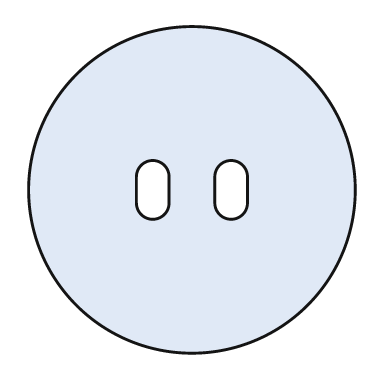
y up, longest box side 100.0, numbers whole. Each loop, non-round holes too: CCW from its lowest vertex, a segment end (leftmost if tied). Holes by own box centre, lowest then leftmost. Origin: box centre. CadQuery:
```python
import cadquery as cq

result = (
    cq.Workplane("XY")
    .moveTo(0.0, 0.0)
    .circle(50.0)
    .moveTo(-17.0, -4.0)
    .threePointArc((-12.0, -9.0), (-7.0, -4.0))
    .lineTo(-7.0, 4.0)
    .threePointArc((-12.0, 9.0), (-17.0, 4.0))
    .close()
    .moveTo(7.0, -4.0)
    .threePointArc((12.0, -9.0), (17.0, -4.0))
    .lineTo(17.0, 4.0)
    .threePointArc((12.0, 9.0), (7.0, 4.0))
    .close()
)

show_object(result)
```